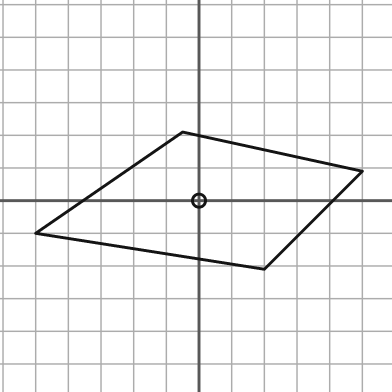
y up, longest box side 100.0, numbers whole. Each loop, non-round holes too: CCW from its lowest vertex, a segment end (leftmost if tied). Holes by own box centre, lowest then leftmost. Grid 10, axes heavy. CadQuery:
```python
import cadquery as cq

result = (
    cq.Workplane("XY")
    .moveTo(20.0, -21.0)
    .lineTo(50.0, 9.0)
    .lineTo(-5.0, 21.0)
    .lineTo(-50.0, -10.0)
    .close()
    .moveTo(0.0, 0.0)
    .circle(2.0)
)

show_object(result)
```